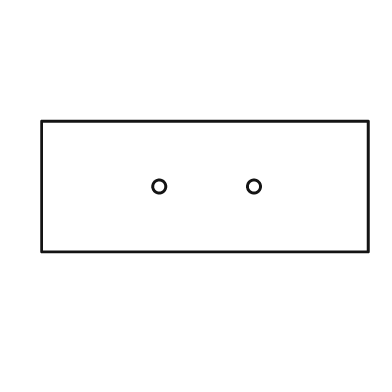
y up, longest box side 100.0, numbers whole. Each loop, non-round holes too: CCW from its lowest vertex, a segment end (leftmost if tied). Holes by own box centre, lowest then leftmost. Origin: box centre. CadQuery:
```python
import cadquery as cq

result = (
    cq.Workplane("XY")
    .moveTo(-50.0, -20.0)
    .lineTo(50.0, -20.0)
    .lineTo(50.0, 20.0)
    .lineTo(-50.0, 20.0)
    .close()
    .moveTo(-14.0, 0.0)
    .circle(2.0)
    .moveTo(15.0, 0.0)
    .circle(2.0)
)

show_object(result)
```